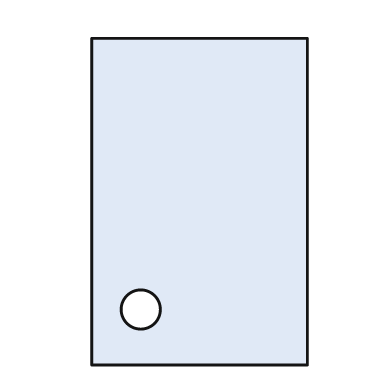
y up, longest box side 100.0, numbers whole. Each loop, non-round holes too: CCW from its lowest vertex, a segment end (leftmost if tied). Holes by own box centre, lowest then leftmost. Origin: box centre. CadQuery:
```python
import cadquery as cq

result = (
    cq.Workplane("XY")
    .moveTo(-33.0, -50.0)
    .lineTo(33.0, -50.0)
    .lineTo(33.0, 50.0)
    .lineTo(-33.0, 50.0)
    .close()
    .moveTo(-18.0, -33.0)
    .circle(6.0)
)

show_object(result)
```